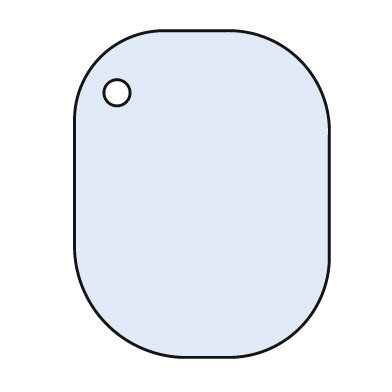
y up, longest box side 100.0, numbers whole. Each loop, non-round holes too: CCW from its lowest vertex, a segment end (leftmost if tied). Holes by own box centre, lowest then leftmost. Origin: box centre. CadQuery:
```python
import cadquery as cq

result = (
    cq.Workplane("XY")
    .moveTo(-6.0, -50.0)
    .lineTo(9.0, -50.0)
    .threePointArc((30.0, -41.0), (39.0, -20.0))
    .lineTo(39.0, 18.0)
    .threePointArc((30.0, 41.0), (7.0, 50.0))
    .lineTo(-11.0, 50.0)
    .threePointArc((-31.0, 42.0), (-39.0, 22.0))
    .lineTo(-39.0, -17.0)
    .threePointArc((-29.0, -40.0), (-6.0, -50.0))
    .close()
    .moveTo(-26.0, 31.0)
    .circle(4.0)
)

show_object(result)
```